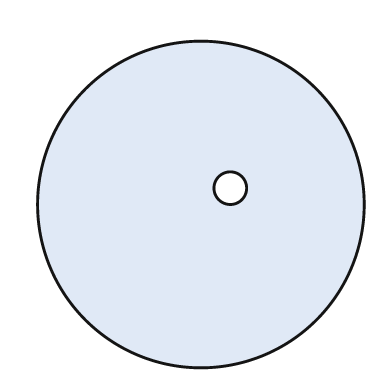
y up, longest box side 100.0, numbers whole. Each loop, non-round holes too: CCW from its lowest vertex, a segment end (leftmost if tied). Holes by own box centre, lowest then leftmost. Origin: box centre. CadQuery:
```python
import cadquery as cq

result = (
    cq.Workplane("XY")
    .moveTo(0.0, 0.0)
    .circle(50.0)
    .moveTo(9.0, 5.0)
    .circle(5.0)
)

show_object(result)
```